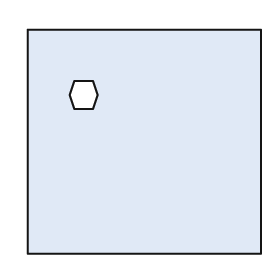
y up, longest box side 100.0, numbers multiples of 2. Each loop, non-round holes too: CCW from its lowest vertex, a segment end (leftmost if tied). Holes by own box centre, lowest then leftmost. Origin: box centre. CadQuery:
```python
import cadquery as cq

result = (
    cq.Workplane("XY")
    .moveTo(-50.0, -48.0)
    .lineTo(50.0, -48.0)
    .lineTo(50.0, 48.0)
    .lineTo(-50.0, 48.0)
    .close()
    .moveTo(-30.0, 14.0)
    .lineTo(-22.0, 14.0)
    .lineTo(-20.0, 20.0)
    .lineTo(-22.0, 26.0)
    .lineTo(-30.0, 26.0)
    .lineTo(-32.0, 20.0)
    .close()
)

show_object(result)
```